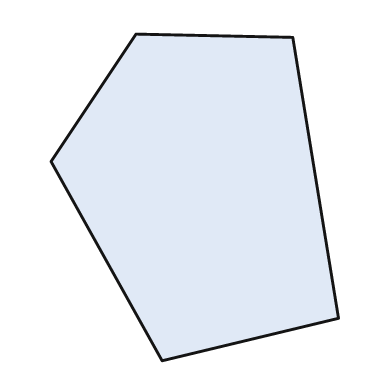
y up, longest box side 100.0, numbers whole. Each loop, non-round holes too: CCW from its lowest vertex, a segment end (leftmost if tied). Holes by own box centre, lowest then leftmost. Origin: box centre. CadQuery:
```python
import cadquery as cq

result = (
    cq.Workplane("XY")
    .moveTo(-10.0, -50.0)
    .lineTo(44.0, -37.0)
    .lineTo(30.0, 49.0)
    .lineTo(-18.0, 50.0)
    .lineTo(-44.0, 11.0)
    .close()
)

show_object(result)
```